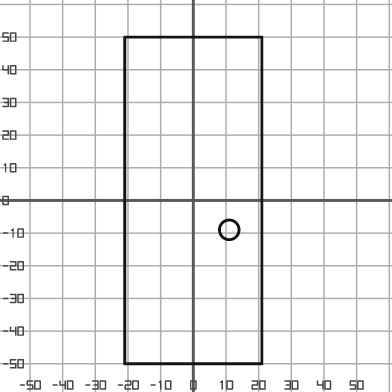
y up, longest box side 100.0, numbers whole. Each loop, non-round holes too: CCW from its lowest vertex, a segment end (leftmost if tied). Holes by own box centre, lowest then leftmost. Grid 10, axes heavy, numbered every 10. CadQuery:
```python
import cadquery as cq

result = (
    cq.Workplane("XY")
    .moveTo(-21.0, -50.0)
    .lineTo(21.0, -50.0)
    .lineTo(21.0, 50.0)
    .lineTo(-21.0, 50.0)
    .close()
    .moveTo(11.0, -9.0)
    .circle(3.0)
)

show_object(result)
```